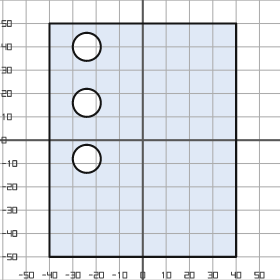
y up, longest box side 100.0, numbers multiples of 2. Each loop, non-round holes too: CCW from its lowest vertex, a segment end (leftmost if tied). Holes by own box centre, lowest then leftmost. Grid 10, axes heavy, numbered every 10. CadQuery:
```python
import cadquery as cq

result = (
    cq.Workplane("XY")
    .moveTo(-40.0, -50.0)
    .lineTo(40.0, -50.0)
    .lineTo(40.0, 50.0)
    .lineTo(-40.0, 50.0)
    .close()
    .moveTo(-24.0, -8.0)
    .circle(6.0)
    .moveTo(-24.0, 16.0)
    .circle(6.0)
    .moveTo(-24.0, 40.0)
    .circle(6.0)
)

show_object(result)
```